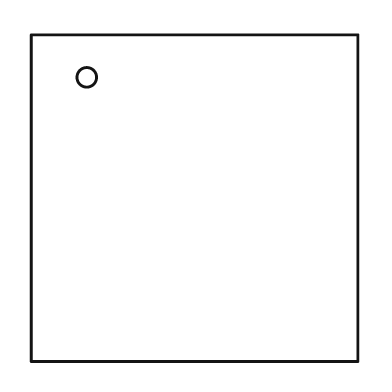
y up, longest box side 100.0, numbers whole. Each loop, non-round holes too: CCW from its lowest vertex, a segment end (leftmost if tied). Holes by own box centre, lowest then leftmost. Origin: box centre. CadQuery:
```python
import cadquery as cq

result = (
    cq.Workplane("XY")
    .moveTo(-50.0, -50.0)
    .lineTo(50.0, -50.0)
    .lineTo(50.0, 50.0)
    .lineTo(-50.0, 50.0)
    .close()
    .moveTo(-33.0, 37.0)
    .circle(3.0)
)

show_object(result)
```